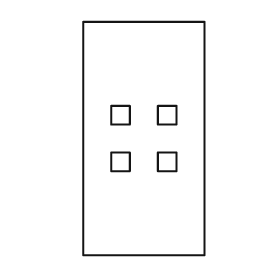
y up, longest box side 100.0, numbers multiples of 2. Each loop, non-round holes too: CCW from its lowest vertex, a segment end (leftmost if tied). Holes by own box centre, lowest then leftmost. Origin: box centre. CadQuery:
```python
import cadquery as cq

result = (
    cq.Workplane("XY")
    .moveTo(-26.0, -50.0)
    .lineTo(26.0, -50.0)
    .lineTo(26.0, 50.0)
    .lineTo(-26.0, 50.0)
    .close()
    .moveTo(-14.0, -14.0)
    .lineTo(-6.0, -14.0)
    .lineTo(-6.0, -6.0)
    .lineTo(-14.0, -6.0)
    .close()
    .moveTo(6.0, -14.0)
    .lineTo(14.0, -14.0)
    .lineTo(14.0, -6.0)
    .lineTo(6.0, -6.0)
    .close()
    .moveTo(-14.0, 6.0)
    .lineTo(-6.0, 6.0)
    .lineTo(-6.0, 14.0)
    .lineTo(-14.0, 14.0)
    .close()
    .moveTo(6.0, 6.0)
    .lineTo(14.0, 6.0)
    .lineTo(14.0, 14.0)
    .lineTo(6.0, 14.0)
    .close()
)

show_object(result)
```